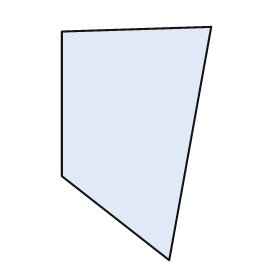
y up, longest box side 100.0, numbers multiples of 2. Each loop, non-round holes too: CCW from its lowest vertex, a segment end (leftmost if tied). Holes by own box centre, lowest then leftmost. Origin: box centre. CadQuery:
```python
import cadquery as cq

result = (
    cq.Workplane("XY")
    .moveTo(14.0, -50.0)
    .lineTo(32.0, 50.0)
    .lineTo(-32.0, 48.0)
    .lineTo(-32.0, -14.0)
    .close()
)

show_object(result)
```